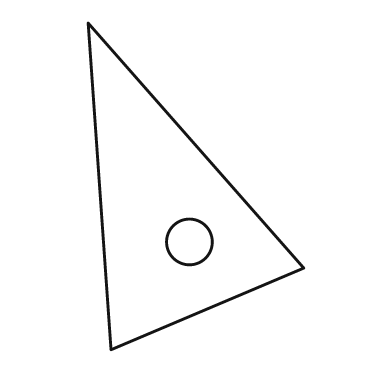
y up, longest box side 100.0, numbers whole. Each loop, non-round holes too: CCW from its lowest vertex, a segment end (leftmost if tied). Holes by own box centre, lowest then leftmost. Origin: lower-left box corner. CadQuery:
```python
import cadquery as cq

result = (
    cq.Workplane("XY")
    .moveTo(7.0, 0.0)
    .lineTo(66.0, 25.0)
    .lineTo(0.0, 100.0)
    .close()
    .moveTo(31.0, 33.0)
    .circle(7.0)
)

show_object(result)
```